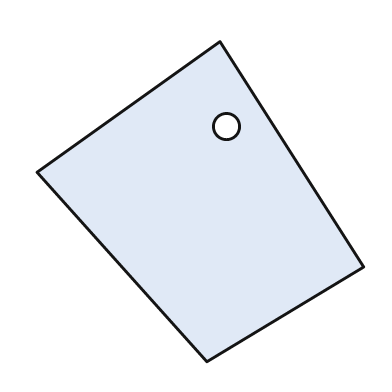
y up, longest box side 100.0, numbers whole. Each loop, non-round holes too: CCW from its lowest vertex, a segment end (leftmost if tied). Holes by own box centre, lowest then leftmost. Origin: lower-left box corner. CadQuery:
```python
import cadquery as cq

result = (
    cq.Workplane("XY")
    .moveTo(52.0, 0.0)
    .lineTo(100.0, 29.0)
    .lineTo(56.0, 98.0)
    .lineTo(0.0, 58.0)
    .close()
    .moveTo(58.0, 72.0)
    .circle(4.0)
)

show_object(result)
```